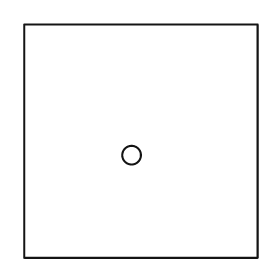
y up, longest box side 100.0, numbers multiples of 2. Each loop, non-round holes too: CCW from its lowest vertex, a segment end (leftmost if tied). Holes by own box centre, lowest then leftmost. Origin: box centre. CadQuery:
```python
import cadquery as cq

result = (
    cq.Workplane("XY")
    .moveTo(-50.0, -50.0)
    .lineTo(50.0, -50.0)
    .lineTo(50.0, 50.0)
    .lineTo(-50.0, 50.0)
    .close()
    .moveTo(-4.0, -6.0)
    .circle(4.0)
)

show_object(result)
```